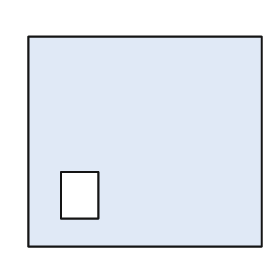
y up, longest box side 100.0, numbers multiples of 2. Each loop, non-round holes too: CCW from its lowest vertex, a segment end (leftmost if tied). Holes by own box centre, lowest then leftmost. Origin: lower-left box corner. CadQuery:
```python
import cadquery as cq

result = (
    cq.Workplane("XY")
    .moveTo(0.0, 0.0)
    .lineTo(100.0, 0.0)
    .lineTo(100.0, 90.0)
    .lineTo(0.0, 90.0)
    .close()
    .moveTo(14.0, 12.0)
    .lineTo(30.0, 12.0)
    .lineTo(30.0, 32.0)
    .lineTo(14.0, 32.0)
    .close()
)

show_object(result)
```